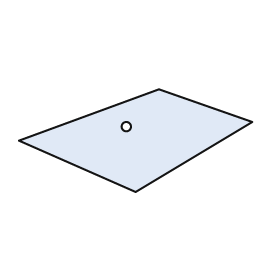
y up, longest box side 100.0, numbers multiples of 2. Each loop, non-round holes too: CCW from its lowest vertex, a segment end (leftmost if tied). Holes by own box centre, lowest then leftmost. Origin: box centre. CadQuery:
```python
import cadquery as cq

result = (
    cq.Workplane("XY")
    .moveTo(0.0, -22.0)
    .lineTo(50.0, 8.0)
    .lineTo(10.0, 22.0)
    .lineTo(-50.0, 0.0)
    .close()
    .moveTo(-4.0, 6.0)
    .circle(2.0)
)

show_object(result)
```